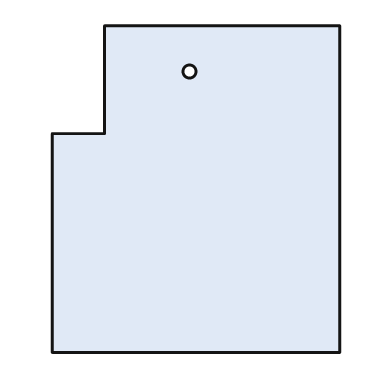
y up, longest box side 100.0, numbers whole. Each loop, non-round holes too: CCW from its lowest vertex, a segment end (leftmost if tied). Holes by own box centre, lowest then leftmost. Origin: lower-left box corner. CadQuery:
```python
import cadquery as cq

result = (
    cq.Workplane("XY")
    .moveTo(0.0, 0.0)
    .lineTo(88.0, 0.0)
    .lineTo(88.0, 100.0)
    .lineTo(16.0, 100.0)
    .lineTo(16.0, 67.0)
    .lineTo(0.0, 67.0)
    .close()
    .moveTo(42.0, 86.0)
    .circle(2.0)
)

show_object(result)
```